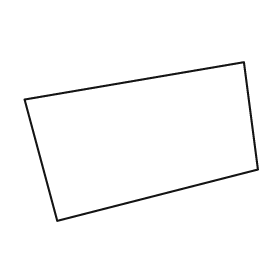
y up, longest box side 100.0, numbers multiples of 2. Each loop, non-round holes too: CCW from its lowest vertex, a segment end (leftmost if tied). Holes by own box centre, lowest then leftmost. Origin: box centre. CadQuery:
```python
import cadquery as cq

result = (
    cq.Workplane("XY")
    .moveTo(-36.0, -34.0)
    .lineTo(50.0, -12.0)
    .lineTo(44.0, 34.0)
    .lineTo(-50.0, 18.0)
    .close()
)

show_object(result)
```